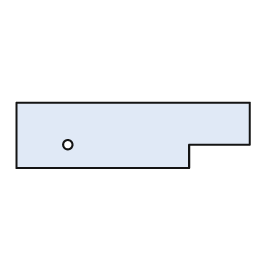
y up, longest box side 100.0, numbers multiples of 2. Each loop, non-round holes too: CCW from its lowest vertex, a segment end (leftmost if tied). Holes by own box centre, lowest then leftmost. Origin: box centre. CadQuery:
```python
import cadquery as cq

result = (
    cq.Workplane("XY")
    .moveTo(-50.0, -14.0)
    .lineTo(24.0, -14.0)
    .lineTo(24.0, -4.0)
    .lineTo(50.0, -4.0)
    .lineTo(50.0, 14.0)
    .lineTo(-50.0, 14.0)
    .close()
    .moveTo(-28.0, -4.0)
    .circle(2.0)
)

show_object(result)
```